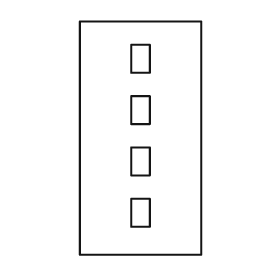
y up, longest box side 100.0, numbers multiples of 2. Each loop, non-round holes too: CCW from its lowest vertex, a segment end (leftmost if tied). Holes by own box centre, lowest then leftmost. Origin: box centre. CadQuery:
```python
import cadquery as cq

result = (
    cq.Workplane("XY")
    .moveTo(-26.0, -50.0)
    .lineTo(26.0, -50.0)
    .lineTo(26.0, 50.0)
    .lineTo(-26.0, 50.0)
    .close()
    .moveTo(-4.0, -38.0)
    .lineTo(4.0, -38.0)
    .lineTo(4.0, -26.0)
    .lineTo(-4.0, -26.0)
    .close()
    .moveTo(-4.0, -16.0)
    .lineTo(4.0, -16.0)
    .lineTo(4.0, -4.0)
    .lineTo(-4.0, -4.0)
    .close()
    .moveTo(-4.0, 6.0)
    .lineTo(4.0, 6.0)
    .lineTo(4.0, 18.0)
    .lineTo(-4.0, 18.0)
    .close()
    .moveTo(-4.0, 28.0)
    .lineTo(4.0, 28.0)
    .lineTo(4.0, 40.0)
    .lineTo(-4.0, 40.0)
    .close()
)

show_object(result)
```